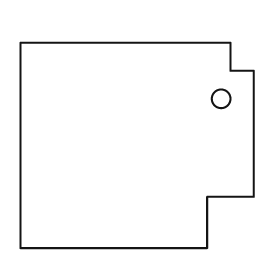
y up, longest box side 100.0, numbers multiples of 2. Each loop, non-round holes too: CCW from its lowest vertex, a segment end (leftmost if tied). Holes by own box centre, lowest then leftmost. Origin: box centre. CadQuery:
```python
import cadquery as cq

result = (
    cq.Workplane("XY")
    .moveTo(-50.0, -44.0)
    .lineTo(30.0, -44.0)
    .lineTo(30.0, -22.0)
    .lineTo(50.0, -22.0)
    .lineTo(50.0, 32.0)
    .lineTo(40.0, 32.0)
    .lineTo(40.0, 44.0)
    .lineTo(-50.0, 44.0)
    .close()
    .moveTo(36.0, 20.0)
    .circle(4.0)
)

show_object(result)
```